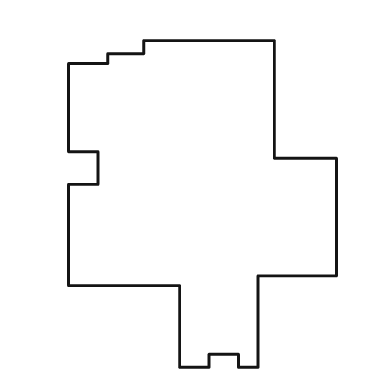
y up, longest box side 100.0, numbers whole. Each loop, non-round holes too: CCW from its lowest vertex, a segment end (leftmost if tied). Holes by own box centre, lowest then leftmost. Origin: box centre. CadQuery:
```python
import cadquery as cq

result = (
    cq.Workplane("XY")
    .moveTo(-7.0, -50.0)
    .lineTo(2.0, -50.0)
    .lineTo(2.0, -46.0)
    .lineTo(11.0, -46.0)
    .lineTo(11.0, -50.0)
    .lineTo(17.0, -50.0)
    .lineTo(17.0, -22.0)
    .lineTo(41.0, -22.0)
    .lineTo(41.0, 14.0)
    .lineTo(22.0, 14.0)
    .lineTo(22.0, 50.0)
    .lineTo(-18.0, 50.0)
    .lineTo(-18.0, 46.0)
    .lineTo(-29.0, 46.0)
    .lineTo(-29.0, 43.0)
    .lineTo(-41.0, 43.0)
    .lineTo(-41.0, 16.0)
    .lineTo(-32.0, 16.0)
    .lineTo(-32.0, 6.0)
    .lineTo(-41.0, 6.0)
    .lineTo(-41.0, -25.0)
    .lineTo(-7.0, -25.0)
    .close()
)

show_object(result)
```